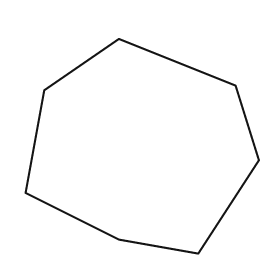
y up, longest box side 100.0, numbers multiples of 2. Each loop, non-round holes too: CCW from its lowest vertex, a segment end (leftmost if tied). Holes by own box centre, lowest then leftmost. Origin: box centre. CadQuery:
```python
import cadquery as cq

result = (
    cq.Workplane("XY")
    .moveTo(24.0, -46.0)
    .lineTo(50.0, -6.0)
    .lineTo(40.0, 26.0)
    .lineTo(-10.0, 46.0)
    .lineTo(-42.0, 24.0)
    .lineTo(-50.0, -20.0)
    .lineTo(-10.0, -40.0)
    .close()
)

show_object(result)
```